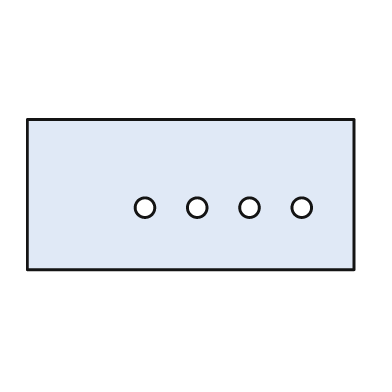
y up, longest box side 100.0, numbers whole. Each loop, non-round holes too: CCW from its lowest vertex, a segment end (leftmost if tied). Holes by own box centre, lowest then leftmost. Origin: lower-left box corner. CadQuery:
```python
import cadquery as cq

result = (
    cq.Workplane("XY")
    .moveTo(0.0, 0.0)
    .lineTo(100.0, 0.0)
    .lineTo(100.0, 46.0)
    .lineTo(0.0, 46.0)
    .close()
    .moveTo(36.0, 19.0)
    .circle(3.0)
    .moveTo(52.0, 19.0)
    .circle(3.0)
    .moveTo(68.0, 19.0)
    .circle(3.0)
    .moveTo(84.0, 19.0)
    .circle(3.0)
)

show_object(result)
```